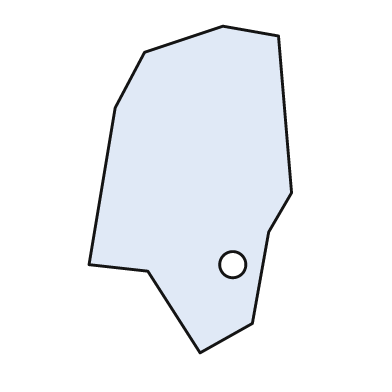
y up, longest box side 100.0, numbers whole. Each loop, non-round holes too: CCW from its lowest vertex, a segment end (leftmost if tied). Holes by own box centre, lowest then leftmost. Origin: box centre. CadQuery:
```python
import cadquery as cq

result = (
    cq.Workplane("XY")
    .moveTo(3.0, -50.0)
    .lineTo(19.0, -41.0)
    .lineTo(24.0, -13.0)
    .lineTo(31.0, -1.0)
    .lineTo(27.0, 47.0)
    .lineTo(10.0, 50.0)
    .lineTo(-14.0, 42.0)
    .lineTo(-23.0, 25.0)
    .lineTo(-31.0, -23.0)
    .lineTo(-13.0, -25.0)
    .close()
    .moveTo(13.0, -23.0)
    .circle(4.0)
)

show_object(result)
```